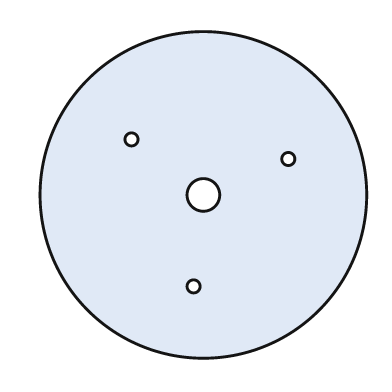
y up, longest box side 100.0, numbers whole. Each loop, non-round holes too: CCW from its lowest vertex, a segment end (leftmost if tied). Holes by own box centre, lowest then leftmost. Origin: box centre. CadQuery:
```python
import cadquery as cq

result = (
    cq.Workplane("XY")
    .moveTo(0.0, 0.0)
    .circle(50.0)
    .moveTo(-3.0, -28.0)
    .circle(2.0)
    .moveTo(0.0, 0.0)
    .circle(5.0)
    .moveTo(26.0, 11.0)
    .circle(2.0)
    .moveTo(-22.0, 17.0)
    .circle(2.0)
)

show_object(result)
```